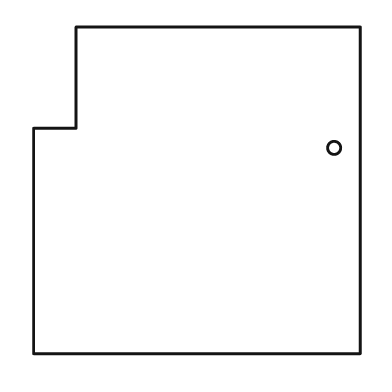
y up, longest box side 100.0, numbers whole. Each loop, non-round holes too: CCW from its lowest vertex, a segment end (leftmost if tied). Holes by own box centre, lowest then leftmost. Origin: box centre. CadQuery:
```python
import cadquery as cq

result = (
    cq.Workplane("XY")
    .moveTo(-50.0, -50.0)
    .lineTo(50.0, -50.0)
    .lineTo(50.0, 50.0)
    .lineTo(-37.0, 50.0)
    .lineTo(-37.0, 19.0)
    .lineTo(-50.0, 19.0)
    .close()
    .moveTo(42.0, 13.0)
    .circle(2.0)
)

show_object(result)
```